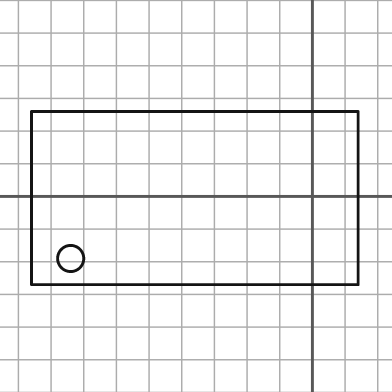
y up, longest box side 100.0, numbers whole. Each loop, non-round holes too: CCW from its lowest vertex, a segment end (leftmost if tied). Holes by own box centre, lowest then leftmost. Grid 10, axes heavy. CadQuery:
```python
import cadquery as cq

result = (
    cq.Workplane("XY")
    .moveTo(-86.0, -27.0)
    .lineTo(14.0, -27.0)
    .lineTo(14.0, 26.0)
    .lineTo(-86.0, 26.0)
    .close()
    .moveTo(-74.0, -19.0)
    .circle(4.0)
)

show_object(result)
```